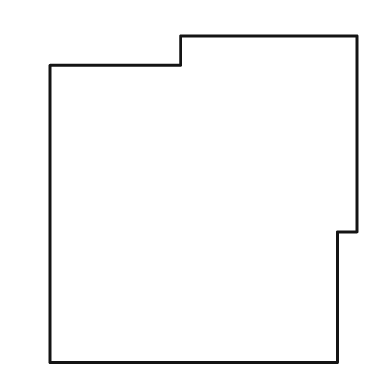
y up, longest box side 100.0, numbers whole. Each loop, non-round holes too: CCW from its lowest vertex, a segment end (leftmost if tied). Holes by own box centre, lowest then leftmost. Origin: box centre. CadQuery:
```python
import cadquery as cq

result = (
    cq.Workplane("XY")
    .moveTo(-47.0, -50.0)
    .lineTo(41.0, -50.0)
    .lineTo(41.0, -10.0)
    .lineTo(47.0, -10.0)
    .lineTo(47.0, 50.0)
    .lineTo(-7.0, 50.0)
    .lineTo(-7.0, 41.0)
    .lineTo(-47.0, 41.0)
    .close()
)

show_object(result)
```